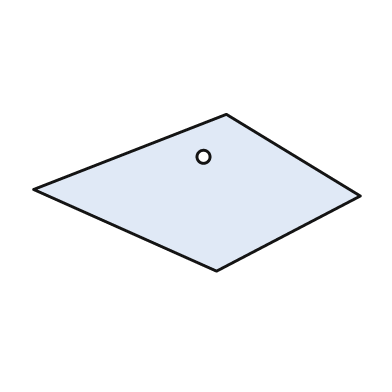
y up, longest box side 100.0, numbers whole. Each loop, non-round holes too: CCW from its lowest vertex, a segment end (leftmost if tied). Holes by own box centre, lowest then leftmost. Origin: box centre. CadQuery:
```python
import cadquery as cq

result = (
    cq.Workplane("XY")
    .moveTo(6.0, -24.0)
    .lineTo(50.0, -1.0)
    .lineTo(9.0, 24.0)
    .lineTo(-50.0, 1.0)
    .close()
    .moveTo(2.0, 11.0)
    .circle(2.0)
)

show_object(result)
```